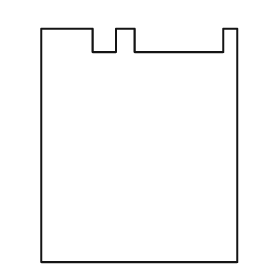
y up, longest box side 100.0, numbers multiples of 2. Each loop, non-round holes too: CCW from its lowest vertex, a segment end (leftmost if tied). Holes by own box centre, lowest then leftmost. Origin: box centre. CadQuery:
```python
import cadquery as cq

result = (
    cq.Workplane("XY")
    .moveTo(-42.0, -50.0)
    .lineTo(42.0, -50.0)
    .lineTo(42.0, 50.0)
    .lineTo(36.0, 50.0)
    .lineTo(36.0, 40.0)
    .lineTo(-2.0, 40.0)
    .lineTo(-2.0, 50.0)
    .lineTo(-10.0, 50.0)
    .lineTo(-10.0, 40.0)
    .lineTo(-20.0, 40.0)
    .lineTo(-20.0, 50.0)
    .lineTo(-42.0, 50.0)
    .close()
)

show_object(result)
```